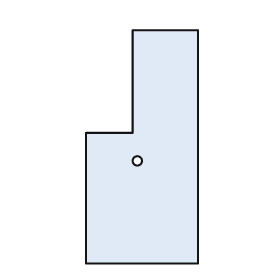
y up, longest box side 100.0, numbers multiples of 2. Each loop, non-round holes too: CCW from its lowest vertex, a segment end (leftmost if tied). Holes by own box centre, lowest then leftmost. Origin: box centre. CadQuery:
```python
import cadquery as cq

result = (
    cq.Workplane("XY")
    .moveTo(-24.0, -50.0)
    .lineTo(24.0, -50.0)
    .lineTo(24.0, 50.0)
    .lineTo(-4.0, 50.0)
    .lineTo(-4.0, 6.0)
    .lineTo(-24.0, 6.0)
    .close()
    .moveTo(-2.0, -6.0)
    .circle(2.0)
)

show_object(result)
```